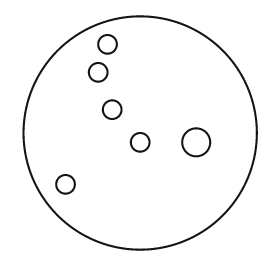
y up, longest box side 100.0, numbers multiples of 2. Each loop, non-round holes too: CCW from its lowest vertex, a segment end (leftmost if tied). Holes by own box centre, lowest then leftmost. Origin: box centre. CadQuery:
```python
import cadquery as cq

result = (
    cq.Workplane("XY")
    .moveTo(0.0, 0.0)
    .circle(50.0)
    .moveTo(-32.0, -22.0)
    .circle(4.0)
    .moveTo(0.0, -4.0)
    .circle(4.0)
    .moveTo(24.0, -4.0)
    .circle(6.0)
    .moveTo(-12.0, 10.0)
    .circle(4.0)
    .moveTo(-18.0, 26.0)
    .circle(4.0)
    .moveTo(-14.0, 38.0)
    .circle(4.0)
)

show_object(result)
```